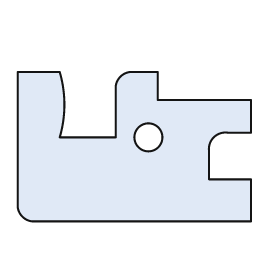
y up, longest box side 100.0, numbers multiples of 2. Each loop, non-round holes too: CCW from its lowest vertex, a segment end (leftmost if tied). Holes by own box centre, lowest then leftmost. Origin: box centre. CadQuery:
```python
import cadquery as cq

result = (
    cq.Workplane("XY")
    .moveTo(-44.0, -32.0)
    .lineTo(50.0, -32.0)
    .lineTo(50.0, -14.0)
    .lineTo(32.0, -14.0)
    .lineTo(32.0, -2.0)
    .threePointArc((34.0, 4.0), (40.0, 6.0))
    .lineTo(50.0, 6.0)
    .lineTo(50.0, 20.0)
    .lineTo(10.0, 20.0)
    .lineTo(10.0, 32.0)
    .lineTo(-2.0, 32.0)
    .threePointArc((-6.0, 30.0), (-8.0, 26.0))
    .lineTo(-8.0, 4.0)
    .lineTo(-32.0, 4.0)
    .threePointArc((-30.0, 18.0), (-32.0, 32.0))
    .lineTo(-50.0, 32.0)
    .lineTo(-50.0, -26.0)
    .threePointArc((-48.0, -30.0), (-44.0, -32.0))
    .close()
    .moveTo(6.0, 4.0)
    .circle(6.0)
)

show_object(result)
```